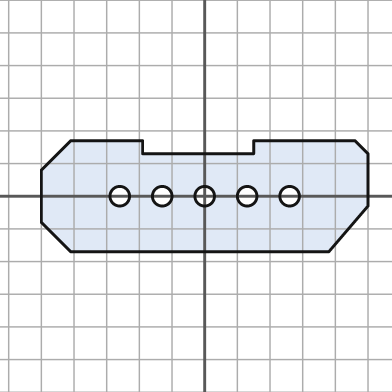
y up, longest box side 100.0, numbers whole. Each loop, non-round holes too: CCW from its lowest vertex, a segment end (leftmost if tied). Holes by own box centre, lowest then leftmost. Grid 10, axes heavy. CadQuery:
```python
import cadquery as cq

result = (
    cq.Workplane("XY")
    .moveTo(-41.0, -17.0)
    .lineTo(38.0, -17.0)
    .lineTo(50.0, -3.0)
    .lineTo(50.0, 13.0)
    .lineTo(46.0, 17.0)
    .lineTo(15.0, 17.0)
    .lineTo(15.0, 13.0)
    .lineTo(-19.0, 13.0)
    .lineTo(-19.0, 17.0)
    .lineTo(-41.0, 17.0)
    .lineTo(-50.0, 8.0)
    .lineTo(-50.0, -8.0)
    .close()
    .moveTo(-26.0, 0.0)
    .circle(3.0)
    .moveTo(-13.0, 0.0)
    .circle(3.0)
    .moveTo(0.0, 0.0)
    .circle(3.0)
    .moveTo(13.0, 0.0)
    .circle(3.0)
    .moveTo(26.0, 0.0)
    .circle(3.0)
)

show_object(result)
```